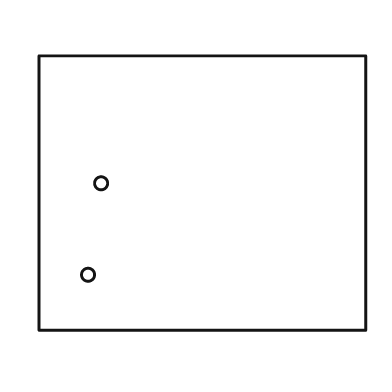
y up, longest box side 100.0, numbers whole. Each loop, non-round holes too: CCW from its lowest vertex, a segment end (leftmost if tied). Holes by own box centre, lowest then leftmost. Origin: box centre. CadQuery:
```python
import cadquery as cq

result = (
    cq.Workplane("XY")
    .moveTo(-50.0, -42.0)
    .lineTo(50.0, -42.0)
    .lineTo(50.0, 42.0)
    .lineTo(-50.0, 42.0)
    .close()
    .moveTo(-35.0, -25.0)
    .circle(2.0)
    .moveTo(-31.0, 3.0)
    .circle(2.0)
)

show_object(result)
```